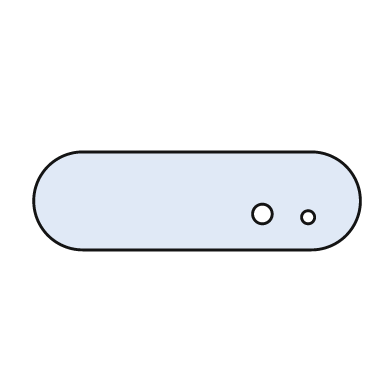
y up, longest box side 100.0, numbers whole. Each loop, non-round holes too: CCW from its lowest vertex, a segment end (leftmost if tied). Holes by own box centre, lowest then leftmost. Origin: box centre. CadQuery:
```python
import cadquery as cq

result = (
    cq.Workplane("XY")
    .moveTo(-35.0, -15.0)
    .lineTo(35.0, -15.0)
    .threePointArc((50.0, 0.0), (35.0, 15.0))
    .lineTo(-35.0, 15.0)
    .threePointArc((-50.0, 0.0), (-35.0, -15.0))
    .close()
    .moveTo(34.0, -5.0)
    .circle(2.0)
    .moveTo(20.0, -4.0)
    .circle(3.0)
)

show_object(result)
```